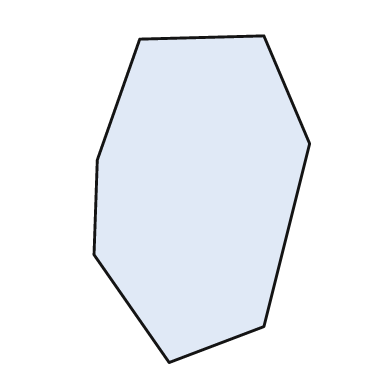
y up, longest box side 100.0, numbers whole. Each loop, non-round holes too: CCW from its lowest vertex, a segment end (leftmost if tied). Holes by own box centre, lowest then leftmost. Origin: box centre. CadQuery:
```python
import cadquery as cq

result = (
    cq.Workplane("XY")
    .moveTo(-10.0, -50.0)
    .lineTo(19.0, -39.0)
    .lineTo(33.0, 17.0)
    .lineTo(19.0, 50.0)
    .lineTo(-19.0, 49.0)
    .lineTo(-32.0, 12.0)
    .lineTo(-33.0, -17.0)
    .close()
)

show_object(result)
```